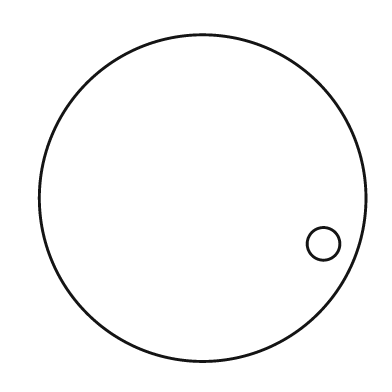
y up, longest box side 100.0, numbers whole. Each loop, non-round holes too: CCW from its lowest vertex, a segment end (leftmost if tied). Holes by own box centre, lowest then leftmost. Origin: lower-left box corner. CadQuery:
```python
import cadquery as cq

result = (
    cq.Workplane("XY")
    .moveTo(50.0, 50.0)
    .circle(50.0)
    .moveTo(87.0, 36.0)
    .circle(5.0)
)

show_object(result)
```